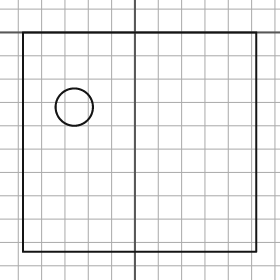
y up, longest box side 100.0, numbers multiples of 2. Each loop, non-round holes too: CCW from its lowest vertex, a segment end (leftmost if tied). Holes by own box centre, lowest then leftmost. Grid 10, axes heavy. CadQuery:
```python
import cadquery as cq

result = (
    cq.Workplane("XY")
    .moveTo(-48.0, -94.0)
    .lineTo(52.0, -94.0)
    .lineTo(52.0, 0.0)
    .lineTo(-48.0, 0.0)
    .close()
    .moveTo(-26.0, -32.0)
    .circle(8.0)
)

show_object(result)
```